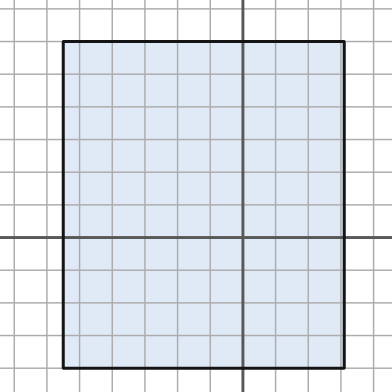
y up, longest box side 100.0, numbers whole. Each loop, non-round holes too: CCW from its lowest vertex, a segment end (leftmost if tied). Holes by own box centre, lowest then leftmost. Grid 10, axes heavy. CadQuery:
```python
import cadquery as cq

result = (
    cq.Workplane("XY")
    .moveTo(-55.0, -40.0)
    .lineTo(31.0, -40.0)
    .lineTo(31.0, 60.0)
    .lineTo(-55.0, 60.0)
    .close()
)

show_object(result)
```